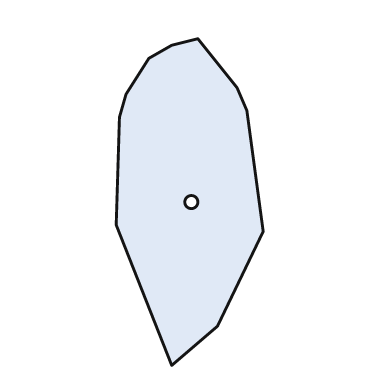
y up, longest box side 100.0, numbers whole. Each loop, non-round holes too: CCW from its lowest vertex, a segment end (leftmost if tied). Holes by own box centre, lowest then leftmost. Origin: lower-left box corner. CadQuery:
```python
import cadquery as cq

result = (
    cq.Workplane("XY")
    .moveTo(17.0, 0.0)
    .lineTo(31.0, 12.0)
    .lineTo(45.0, 41.0)
    .lineTo(40.0, 78.0)
    .lineTo(37.0, 85.0)
    .lineTo(25.0, 100.0)
    .lineTo(17.0, 98.0)
    .lineTo(10.0, 94.0)
    .lineTo(3.0, 83.0)
    .lineTo(1.0, 76.0)
    .lineTo(0.0, 43.0)
    .close()
    .moveTo(23.0, 50.0)
    .circle(2.0)
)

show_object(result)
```